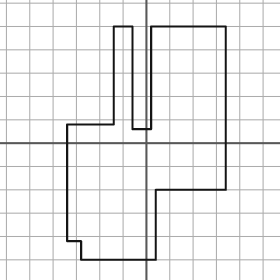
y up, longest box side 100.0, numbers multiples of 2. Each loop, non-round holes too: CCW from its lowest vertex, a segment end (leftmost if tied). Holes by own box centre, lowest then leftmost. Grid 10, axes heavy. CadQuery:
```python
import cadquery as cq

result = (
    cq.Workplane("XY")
    .moveTo(-28.0, -50.0)
    .lineTo(4.0, -50.0)
    .lineTo(4.0, -20.0)
    .lineTo(34.0, -20.0)
    .lineTo(34.0, 50.0)
    .lineTo(2.0, 50.0)
    .lineTo(2.0, 6.0)
    .lineTo(-6.0, 6.0)
    .lineTo(-6.0, 50.0)
    .lineTo(-14.0, 50.0)
    .lineTo(-14.0, 8.0)
    .lineTo(-34.0, 8.0)
    .lineTo(-34.0, -42.0)
    .lineTo(-28.0, -42.0)
    .close()
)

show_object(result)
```